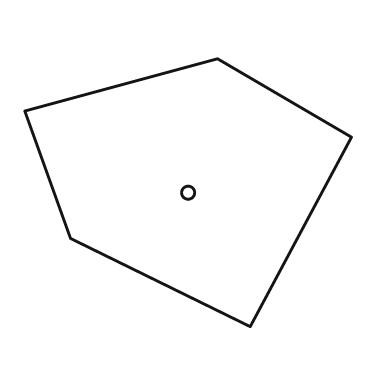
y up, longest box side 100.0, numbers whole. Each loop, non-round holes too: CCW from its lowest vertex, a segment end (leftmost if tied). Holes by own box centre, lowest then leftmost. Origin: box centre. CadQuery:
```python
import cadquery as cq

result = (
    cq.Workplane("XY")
    .moveTo(19.0, -41.0)
    .lineTo(50.0, 17.0)
    .lineTo(9.0, 41.0)
    .lineTo(-50.0, 25.0)
    .lineTo(-36.0, -14.0)
    .close()
    .moveTo(0.0, 0.0)
    .circle(2.0)
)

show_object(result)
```